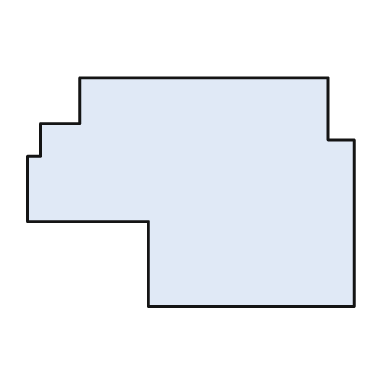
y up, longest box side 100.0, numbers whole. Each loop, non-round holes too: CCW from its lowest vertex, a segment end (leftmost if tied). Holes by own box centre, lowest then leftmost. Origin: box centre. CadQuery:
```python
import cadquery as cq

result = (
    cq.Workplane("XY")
    .moveTo(-13.0, -35.0)
    .lineTo(50.0, -35.0)
    .lineTo(50.0, 16.0)
    .lineTo(42.0, 16.0)
    .lineTo(42.0, 35.0)
    .lineTo(-34.0, 35.0)
    .lineTo(-34.0, 21.0)
    .lineTo(-46.0, 21.0)
    .lineTo(-46.0, 11.0)
    .lineTo(-50.0, 11.0)
    .lineTo(-50.0, -9.0)
    .lineTo(-13.0, -9.0)
    .close()
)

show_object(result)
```